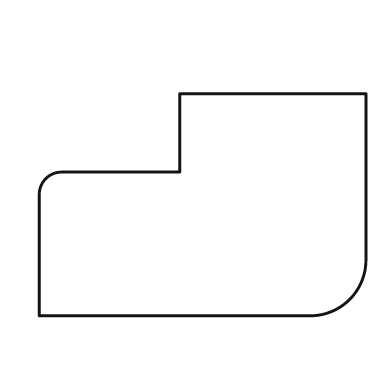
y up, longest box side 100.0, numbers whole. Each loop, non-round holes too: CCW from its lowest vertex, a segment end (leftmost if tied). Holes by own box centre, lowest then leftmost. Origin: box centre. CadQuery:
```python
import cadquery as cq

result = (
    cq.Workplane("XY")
    .moveTo(-50.0, -34.0)
    .lineTo(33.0, -34.0)
    .threePointArc((45.0, -29.0), (50.0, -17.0))
    .lineTo(50.0, 34.0)
    .lineTo(-7.0, 34.0)
    .lineTo(-7.0, 10.0)
    .lineTo(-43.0, 10.0)
    .threePointArc((-48.0, 8.0), (-50.0, 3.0))
    .close()
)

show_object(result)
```